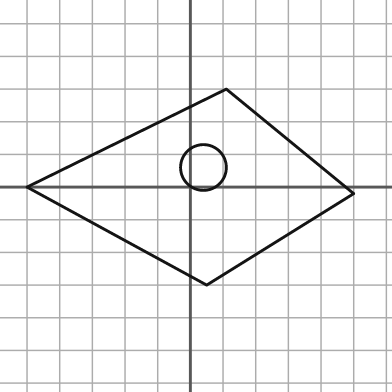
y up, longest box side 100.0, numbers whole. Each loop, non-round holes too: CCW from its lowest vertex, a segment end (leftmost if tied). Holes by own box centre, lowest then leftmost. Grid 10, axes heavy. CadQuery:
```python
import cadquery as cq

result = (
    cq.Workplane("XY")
    .moveTo(5.0, -30.0)
    .lineTo(50.0, -2.0)
    .lineTo(11.0, 30.0)
    .lineTo(-50.0, 0.0)
    .close()
    .moveTo(4.0, 6.0)
    .circle(7.0)
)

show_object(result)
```